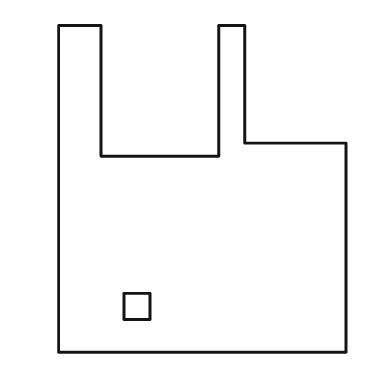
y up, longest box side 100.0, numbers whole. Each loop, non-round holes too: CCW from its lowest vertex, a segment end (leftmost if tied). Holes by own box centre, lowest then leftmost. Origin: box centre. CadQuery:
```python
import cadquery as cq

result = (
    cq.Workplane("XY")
    .moveTo(-44.0, -50.0)
    .lineTo(44.0, -50.0)
    .lineTo(44.0, 14.0)
    .lineTo(13.0, 14.0)
    .lineTo(13.0, 50.0)
    .lineTo(5.0, 50.0)
    .lineTo(5.0, 10.0)
    .lineTo(-31.0, 10.0)
    .lineTo(-31.0, 50.0)
    .lineTo(-44.0, 50.0)
    .close()
    .moveTo(-24.0, -40.0)
    .lineTo(-16.0, -40.0)
    .lineTo(-16.0, -32.0)
    .lineTo(-24.0, -32.0)
    .close()
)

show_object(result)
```